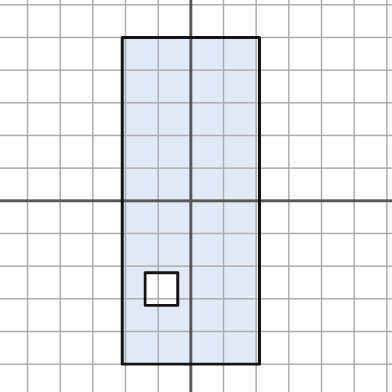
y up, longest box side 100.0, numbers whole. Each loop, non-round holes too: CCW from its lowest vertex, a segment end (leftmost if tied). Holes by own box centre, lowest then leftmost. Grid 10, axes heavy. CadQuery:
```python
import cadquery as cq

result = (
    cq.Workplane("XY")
    .moveTo(-21.0, -50.0)
    .lineTo(21.0, -50.0)
    .lineTo(21.0, 50.0)
    .lineTo(-21.0, 50.0)
    .close()
    .moveTo(-14.0, -32.0)
    .lineTo(-4.0, -32.0)
    .lineTo(-4.0, -22.0)
    .lineTo(-14.0, -22.0)
    .close()
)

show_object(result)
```